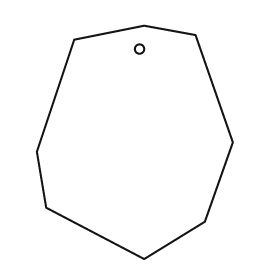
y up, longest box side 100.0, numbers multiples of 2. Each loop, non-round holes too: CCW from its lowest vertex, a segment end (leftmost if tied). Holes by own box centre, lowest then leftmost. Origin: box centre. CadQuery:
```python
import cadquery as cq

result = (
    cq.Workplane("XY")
    .moveTo(4.0, -50.0)
    .lineTo(30.0, -34.0)
    .lineTo(42.0, 0.0)
    .lineTo(26.0, 46.0)
    .lineTo(4.0, 50.0)
    .lineTo(-26.0, 44.0)
    .lineTo(-42.0, -4.0)
    .lineTo(-38.0, -28.0)
    .close()
    .moveTo(2.0, 40.0)
    .circle(2.0)
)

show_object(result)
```